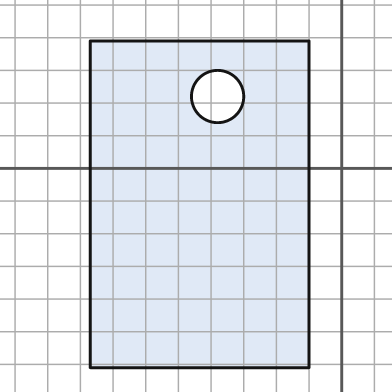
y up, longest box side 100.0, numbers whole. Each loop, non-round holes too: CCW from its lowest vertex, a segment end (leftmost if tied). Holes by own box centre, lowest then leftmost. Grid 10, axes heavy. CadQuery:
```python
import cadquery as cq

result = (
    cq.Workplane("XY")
    .moveTo(-77.0, -61.0)
    .lineTo(-10.0, -61.0)
    .lineTo(-10.0, 39.0)
    .lineTo(-77.0, 39.0)
    .close()
    .moveTo(-38.0, 22.0)
    .circle(8.0)
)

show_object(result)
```